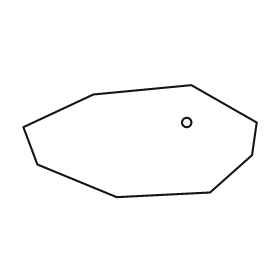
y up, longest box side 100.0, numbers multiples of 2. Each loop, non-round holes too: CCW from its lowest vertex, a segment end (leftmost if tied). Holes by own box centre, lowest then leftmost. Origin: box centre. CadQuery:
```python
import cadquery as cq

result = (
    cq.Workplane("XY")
    .moveTo(-10.0, -24.0)
    .lineTo(30.0, -22.0)
    .lineTo(48.0, -6.0)
    .lineTo(50.0, 8.0)
    .lineTo(22.0, 24.0)
    .lineTo(-20.0, 20.0)
    .lineTo(-50.0, 6.0)
    .lineTo(-44.0, -10.0)
    .close()
    .moveTo(20.0, 8.0)
    .circle(2.0)
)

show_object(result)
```